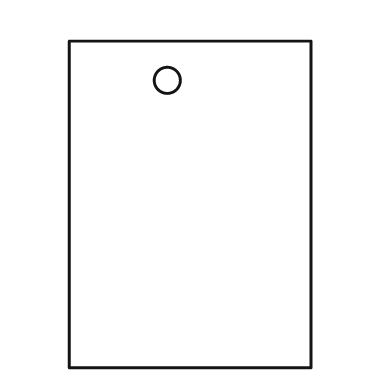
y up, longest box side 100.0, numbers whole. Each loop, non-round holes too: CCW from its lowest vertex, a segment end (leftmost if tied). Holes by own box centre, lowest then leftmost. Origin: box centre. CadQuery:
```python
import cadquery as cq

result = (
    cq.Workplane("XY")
    .moveTo(-37.0, -50.0)
    .lineTo(37.0, -50.0)
    .lineTo(37.0, 50.0)
    .lineTo(-37.0, 50.0)
    .close()
    .moveTo(-7.0, 38.0)
    .circle(4.0)
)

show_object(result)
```